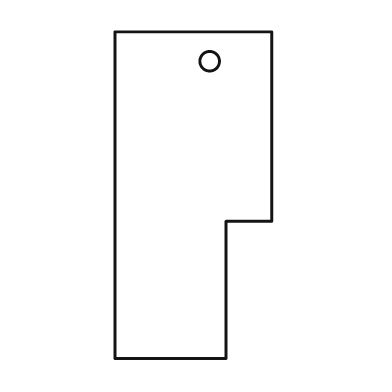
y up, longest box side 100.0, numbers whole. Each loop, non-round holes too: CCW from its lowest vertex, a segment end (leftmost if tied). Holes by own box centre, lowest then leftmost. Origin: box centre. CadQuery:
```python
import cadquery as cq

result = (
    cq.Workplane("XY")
    .moveTo(-24.0, -50.0)
    .lineTo(10.0, -50.0)
    .lineTo(10.0, -8.0)
    .lineTo(24.0, -8.0)
    .lineTo(24.0, 50.0)
    .lineTo(-24.0, 50.0)
    .close()
    .moveTo(5.0, 41.0)
    .circle(3.0)
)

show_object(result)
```